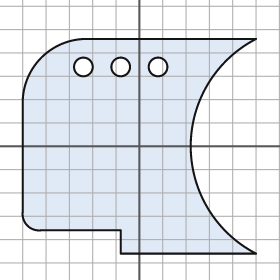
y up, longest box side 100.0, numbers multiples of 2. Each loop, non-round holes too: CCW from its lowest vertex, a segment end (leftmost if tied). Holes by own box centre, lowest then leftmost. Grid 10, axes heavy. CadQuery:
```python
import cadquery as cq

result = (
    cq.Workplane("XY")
    .moveTo(-8.0, -46.0)
    .lineTo(50.0, -46.0)
    .threePointArc((22.0, 0.0), (50.0, 46.0))
    .lineTo(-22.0, 46.0)
    .threePointArc((-42.0, 38.0), (-50.0, 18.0))
    .lineTo(-50.0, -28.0)
    .threePointArc((-48.0, -34.0), (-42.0, -36.0))
    .lineTo(-8.0, -36.0)
    .close()
    .moveTo(-24.0, 34.0)
    .circle(4.0)
    .moveTo(-8.0, 34.0)
    .circle(4.0)
    .moveTo(8.0, 34.0)
    .circle(4.0)
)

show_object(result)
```